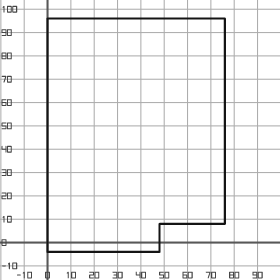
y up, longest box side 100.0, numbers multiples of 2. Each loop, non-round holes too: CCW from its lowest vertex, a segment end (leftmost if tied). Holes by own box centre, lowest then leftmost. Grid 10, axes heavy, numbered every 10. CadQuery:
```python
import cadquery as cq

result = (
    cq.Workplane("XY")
    .moveTo(0.0, -4.0)
    .lineTo(48.0, -4.0)
    .lineTo(48.0, 8.0)
    .lineTo(76.0, 8.0)
    .lineTo(76.0, 96.0)
    .lineTo(0.0, 96.0)
    .close()
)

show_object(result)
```